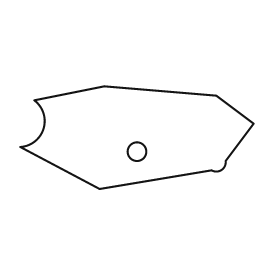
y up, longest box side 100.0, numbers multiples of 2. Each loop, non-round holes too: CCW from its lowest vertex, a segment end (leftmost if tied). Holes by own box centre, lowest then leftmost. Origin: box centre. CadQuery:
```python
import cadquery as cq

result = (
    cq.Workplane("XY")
    .moveTo(-16.0, -22.0)
    .lineTo(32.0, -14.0)
    .threePointArc((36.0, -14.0), (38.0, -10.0))
    .lineTo(50.0, 6.0)
    .lineTo(34.0, 18.0)
    .lineTo(-14.0, 22.0)
    .lineTo(-44.0, 16.0)
    .threePointArc((-40.0, 4.0), (-50.0, -4.0))
    .close()
    .moveTo(0.0, -6.0)
    .circle(4.0)
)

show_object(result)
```